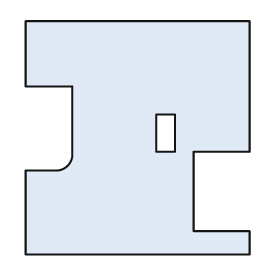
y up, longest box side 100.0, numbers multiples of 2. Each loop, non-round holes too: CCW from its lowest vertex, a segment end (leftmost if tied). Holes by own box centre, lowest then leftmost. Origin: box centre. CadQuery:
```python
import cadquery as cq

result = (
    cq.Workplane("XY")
    .moveTo(-48.0, -50.0)
    .lineTo(48.0, -50.0)
    .lineTo(48.0, -40.0)
    .lineTo(24.0, -40.0)
    .lineTo(24.0, -6.0)
    .lineTo(48.0, -6.0)
    .lineTo(48.0, 50.0)
    .lineTo(-48.0, 50.0)
    .lineTo(-48.0, 22.0)
    .lineTo(-28.0, 22.0)
    .lineTo(-28.0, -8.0)
    .threePointArc((-30.0, -12.0), (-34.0, -14.0))
    .lineTo(-48.0, -14.0)
    .close()
    .moveTo(8.0, -6.0)
    .lineTo(16.0, -6.0)
    .lineTo(16.0, 10.0)
    .lineTo(8.0, 10.0)
    .close()
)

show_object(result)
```